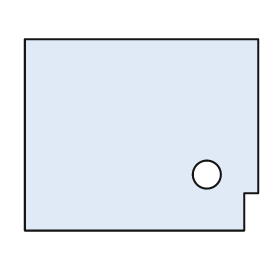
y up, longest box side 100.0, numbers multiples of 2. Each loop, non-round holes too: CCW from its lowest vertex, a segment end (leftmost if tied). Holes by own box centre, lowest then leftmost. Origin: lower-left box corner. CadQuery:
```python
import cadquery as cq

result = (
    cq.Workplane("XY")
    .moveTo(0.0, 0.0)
    .lineTo(94.0, 0.0)
    .lineTo(94.0, 16.0)
    .lineTo(100.0, 16.0)
    .lineTo(100.0, 82.0)
    .lineTo(0.0, 82.0)
    .close()
    .moveTo(78.0, 24.0)
    .circle(6.0)
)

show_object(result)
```